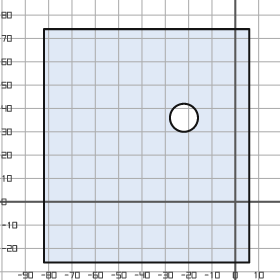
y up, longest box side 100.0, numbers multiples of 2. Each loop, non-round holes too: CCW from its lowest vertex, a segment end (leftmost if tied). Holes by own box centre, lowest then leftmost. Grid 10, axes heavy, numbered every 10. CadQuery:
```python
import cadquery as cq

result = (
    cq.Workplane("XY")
    .moveTo(-82.0, -26.0)
    .lineTo(6.0, -26.0)
    .lineTo(6.0, 74.0)
    .lineTo(-82.0, 74.0)
    .close()
    .moveTo(-22.0, 36.0)
    .circle(6.0)
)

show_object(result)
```